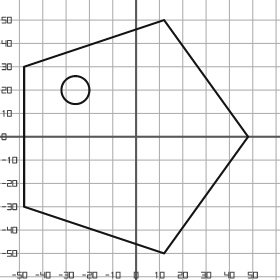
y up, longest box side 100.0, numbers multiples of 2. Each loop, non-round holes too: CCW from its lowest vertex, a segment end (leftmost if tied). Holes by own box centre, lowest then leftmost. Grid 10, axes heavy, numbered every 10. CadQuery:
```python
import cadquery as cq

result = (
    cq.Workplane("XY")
    .moveTo(12.0, -50.0)
    .lineTo(48.0, 0.0)
    .lineTo(12.0, 50.0)
    .lineTo(-48.0, 30.0)
    .lineTo(-48.0, -30.0)
    .close()
    .moveTo(-26.0, 20.0)
    .circle(6.0)
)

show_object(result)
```